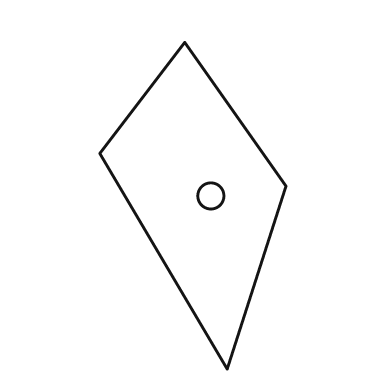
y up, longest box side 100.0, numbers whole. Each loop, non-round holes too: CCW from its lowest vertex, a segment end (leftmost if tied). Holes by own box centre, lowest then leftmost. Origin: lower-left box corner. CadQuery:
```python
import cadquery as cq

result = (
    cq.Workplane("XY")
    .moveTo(39.0, 0.0)
    .lineTo(57.0, 56.0)
    .lineTo(26.0, 100.0)
    .lineTo(0.0, 66.0)
    .close()
    .moveTo(34.0, 53.0)
    .circle(4.0)
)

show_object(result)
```